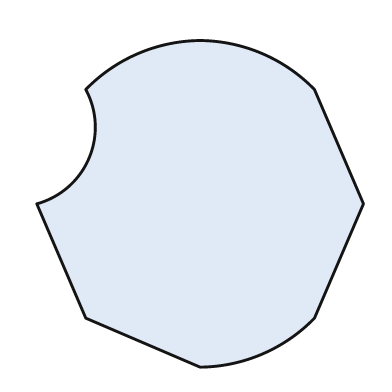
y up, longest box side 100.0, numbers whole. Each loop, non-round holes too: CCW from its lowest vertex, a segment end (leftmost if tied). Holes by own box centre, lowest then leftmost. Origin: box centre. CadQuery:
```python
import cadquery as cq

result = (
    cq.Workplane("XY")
    .moveTo(0.0, -50.0)
    .threePointArc((19.0, -46.0), (35.0, -35.0))
    .lineTo(50.0, 0.0)
    .lineTo(35.0, 35.0)
    .threePointArc((19.0, 46.0), (0.0, 50.0))
    .threePointArc((-19.0, 46.0), (-35.0, 35.0))
    .threePointArc((-34.0, 14.0), (-50.0, 0.0))
    .lineTo(-35.0, -35.0)
    .close()
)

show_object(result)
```